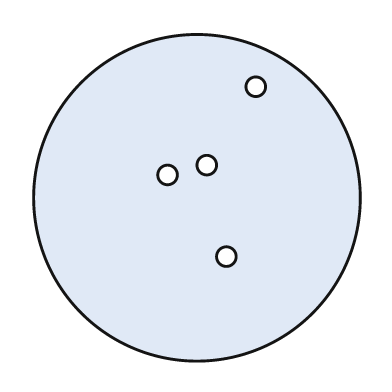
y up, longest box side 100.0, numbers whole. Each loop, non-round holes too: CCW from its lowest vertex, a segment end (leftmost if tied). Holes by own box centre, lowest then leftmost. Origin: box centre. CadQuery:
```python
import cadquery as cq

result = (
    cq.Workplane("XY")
    .moveTo(0.0, 0.0)
    .circle(50.0)
    .moveTo(9.0, -18.0)
    .circle(3.0)
    .moveTo(-9.0, 7.0)
    .circle(3.0)
    .moveTo(3.0, 10.0)
    .circle(3.0)
    .moveTo(18.0, 34.0)
    .circle(3.0)
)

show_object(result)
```